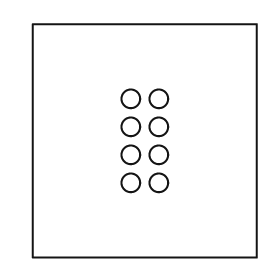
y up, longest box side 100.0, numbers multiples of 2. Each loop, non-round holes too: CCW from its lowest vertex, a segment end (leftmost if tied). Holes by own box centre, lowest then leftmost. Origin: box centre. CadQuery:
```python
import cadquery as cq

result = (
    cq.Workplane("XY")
    .moveTo(-48.0, -50.0)
    .lineTo(48.0, -50.0)
    .lineTo(48.0, 50.0)
    .lineTo(-48.0, 50.0)
    .close()
    .moveTo(-6.0, -18.0)
    .circle(4.0)
    .moveTo(6.0, -18.0)
    .circle(4.0)
    .moveTo(-6.0, -6.0)
    .circle(4.0)
    .moveTo(6.0, -6.0)
    .circle(4.0)
    .moveTo(-6.0, 6.0)
    .circle(4.0)
    .moveTo(6.0, 6.0)
    .circle(4.0)
    .moveTo(-6.0, 18.0)
    .circle(4.0)
    .moveTo(6.0, 18.0)
    .circle(4.0)
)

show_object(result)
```